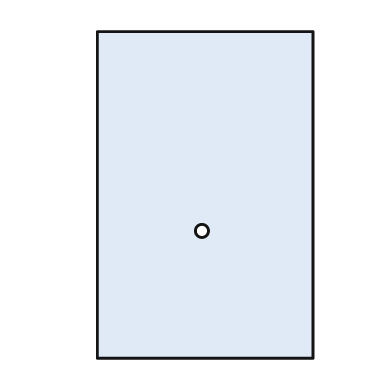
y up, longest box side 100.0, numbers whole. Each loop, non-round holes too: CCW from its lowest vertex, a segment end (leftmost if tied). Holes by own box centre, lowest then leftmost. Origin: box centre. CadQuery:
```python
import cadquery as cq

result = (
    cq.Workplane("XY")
    .moveTo(-33.0, -50.0)
    .lineTo(33.0, -50.0)
    .lineTo(33.0, 50.0)
    .lineTo(-33.0, 50.0)
    .close()
    .moveTo(-1.0, -11.0)
    .circle(2.0)
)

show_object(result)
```